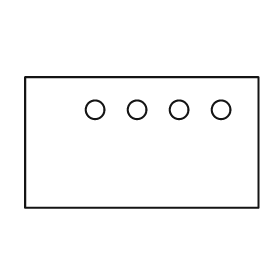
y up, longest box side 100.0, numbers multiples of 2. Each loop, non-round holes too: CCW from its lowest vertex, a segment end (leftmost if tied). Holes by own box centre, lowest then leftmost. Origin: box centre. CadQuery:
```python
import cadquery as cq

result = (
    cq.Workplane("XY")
    .moveTo(-50.0, -28.0)
    .lineTo(50.0, -28.0)
    .lineTo(50.0, 28.0)
    .lineTo(-50.0, 28.0)
    .close()
    .moveTo(-20.0, 14.0)
    .circle(4.0)
    .moveTo(-2.0, 14.0)
    .circle(4.0)
    .moveTo(16.0, 14.0)
    .circle(4.0)
    .moveTo(34.0, 14.0)
    .circle(4.0)
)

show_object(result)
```